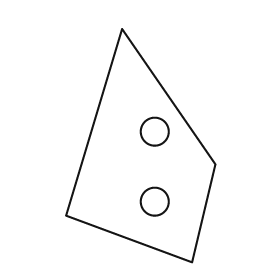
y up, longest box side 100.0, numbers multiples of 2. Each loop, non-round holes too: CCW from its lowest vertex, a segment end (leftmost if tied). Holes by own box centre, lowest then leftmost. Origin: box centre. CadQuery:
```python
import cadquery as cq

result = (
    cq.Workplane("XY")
    .moveTo(22.0, -50.0)
    .lineTo(32.0, -8.0)
    .lineTo(-8.0, 50.0)
    .lineTo(-32.0, -30.0)
    .close()
    .moveTo(6.0, -24.0)
    .circle(6.0)
    .moveTo(6.0, 6.0)
    .circle(6.0)
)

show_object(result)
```